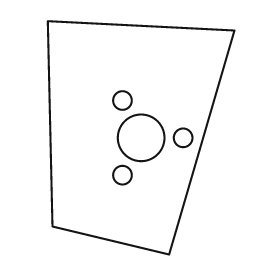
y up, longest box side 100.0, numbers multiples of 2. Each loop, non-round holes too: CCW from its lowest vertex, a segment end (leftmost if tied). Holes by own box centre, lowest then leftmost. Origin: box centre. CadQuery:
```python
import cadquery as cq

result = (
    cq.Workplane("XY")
    .moveTo(12.0, -50.0)
    .lineTo(40.0, 46.0)
    .lineTo(-40.0, 50.0)
    .lineTo(-38.0, -38.0)
    .close()
    .moveTo(-8.0, -16.0)
    .circle(4.0)
    .moveTo(0.0, 0.0)
    .circle(10.0)
    .moveTo(18.0, 0.0)
    .circle(4.0)
    .moveTo(-8.0, 16.0)
    .circle(4.0)
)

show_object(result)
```